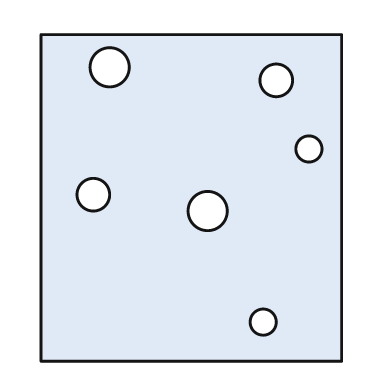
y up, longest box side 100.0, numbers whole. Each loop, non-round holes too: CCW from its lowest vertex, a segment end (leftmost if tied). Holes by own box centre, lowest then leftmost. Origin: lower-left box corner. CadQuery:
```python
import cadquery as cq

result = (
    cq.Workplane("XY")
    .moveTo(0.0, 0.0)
    .lineTo(92.0, 0.0)
    .lineTo(92.0, 100.0)
    .lineTo(0.0, 100.0)
    .close()
    .moveTo(68.0, 12.0)
    .circle(4.0)
    .moveTo(51.0, 46.0)
    .circle(6.0)
    .moveTo(16.0, 51.0)
    .circle(5.0)
    .moveTo(82.0, 65.0)
    .circle(4.0)
    .moveTo(72.0, 86.0)
    .circle(5.0)
    .moveTo(21.0, 90.0)
    .circle(6.0)
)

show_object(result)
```